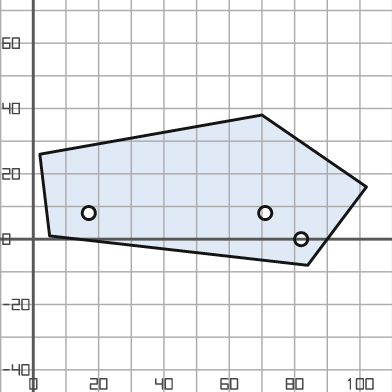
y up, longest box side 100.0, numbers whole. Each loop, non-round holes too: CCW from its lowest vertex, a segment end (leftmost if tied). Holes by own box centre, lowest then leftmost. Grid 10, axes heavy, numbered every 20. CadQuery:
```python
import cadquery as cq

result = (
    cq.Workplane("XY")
    .moveTo(84.0, -8.0)
    .lineTo(102.0, 16.0)
    .lineTo(70.0, 38.0)
    .lineTo(2.0, 26.0)
    .lineTo(5.0, 1.0)
    .close()
    .moveTo(82.0, 0.0)
    .circle(2.0)
    .moveTo(17.0, 8.0)
    .circle(2.0)
    .moveTo(71.0, 8.0)
    .circle(2.0)
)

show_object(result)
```